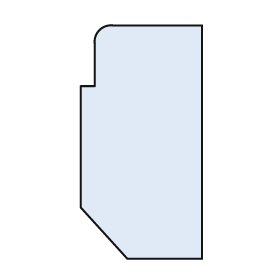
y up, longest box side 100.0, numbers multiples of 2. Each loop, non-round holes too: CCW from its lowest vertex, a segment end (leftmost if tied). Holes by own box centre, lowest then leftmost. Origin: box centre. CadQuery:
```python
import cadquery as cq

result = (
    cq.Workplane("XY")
    .moveTo(-6.0, -50.0)
    .lineTo(26.0, -50.0)
    .lineTo(26.0, 50.0)
    .lineTo(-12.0, 50.0)
    .threePointArc((-18.0, 48.0), (-20.0, 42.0))
    .lineTo(-20.0, 24.0)
    .lineTo(-26.0, 24.0)
    .lineTo(-26.0, -28.0)
    .close()
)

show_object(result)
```